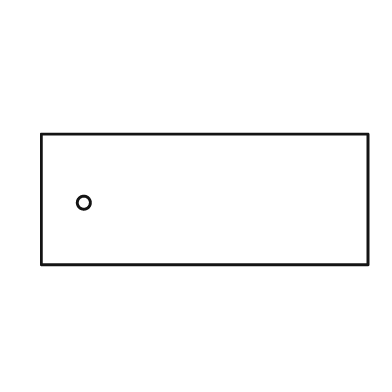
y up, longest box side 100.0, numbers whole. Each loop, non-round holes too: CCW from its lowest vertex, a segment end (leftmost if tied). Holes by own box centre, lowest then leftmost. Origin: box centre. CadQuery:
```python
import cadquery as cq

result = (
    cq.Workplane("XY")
    .moveTo(-50.0, -20.0)
    .lineTo(50.0, -20.0)
    .lineTo(50.0, 20.0)
    .lineTo(-50.0, 20.0)
    .close()
    .moveTo(-37.0, -1.0)
    .circle(2.0)
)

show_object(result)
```